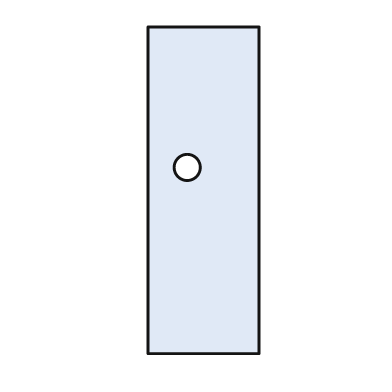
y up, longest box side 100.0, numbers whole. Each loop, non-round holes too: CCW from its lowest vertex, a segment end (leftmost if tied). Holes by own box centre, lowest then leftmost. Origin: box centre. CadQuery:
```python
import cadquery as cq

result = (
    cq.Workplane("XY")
    .moveTo(-17.0, -50.0)
    .lineTo(17.0, -50.0)
    .lineTo(17.0, 50.0)
    .lineTo(-17.0, 50.0)
    .close()
    .moveTo(-5.0, 7.0)
    .circle(4.0)
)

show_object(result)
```